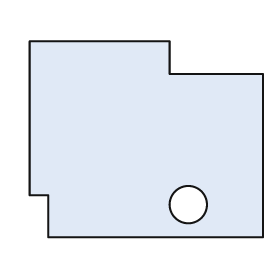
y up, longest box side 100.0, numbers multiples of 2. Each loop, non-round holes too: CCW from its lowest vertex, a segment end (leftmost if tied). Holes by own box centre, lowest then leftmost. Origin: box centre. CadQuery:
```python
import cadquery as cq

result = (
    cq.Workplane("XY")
    .moveTo(-42.0, -42.0)
    .lineTo(50.0, -42.0)
    .lineTo(50.0, 28.0)
    .lineTo(10.0, 28.0)
    .lineTo(10.0, 42.0)
    .lineTo(-50.0, 42.0)
    .lineTo(-50.0, -24.0)
    .lineTo(-42.0, -24.0)
    .close()
    .moveTo(18.0, -28.0)
    .circle(8.0)
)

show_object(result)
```